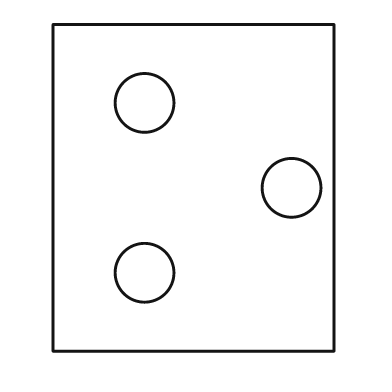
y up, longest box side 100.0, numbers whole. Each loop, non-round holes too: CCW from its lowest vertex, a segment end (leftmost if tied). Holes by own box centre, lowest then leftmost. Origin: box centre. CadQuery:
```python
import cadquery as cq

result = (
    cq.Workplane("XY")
    .moveTo(-43.0, -50.0)
    .lineTo(43.0, -50.0)
    .lineTo(43.0, 50.0)
    .lineTo(-43.0, 50.0)
    .close()
    .moveTo(-15.0, -26.0)
    .circle(9.0)
    .moveTo(30.0, 0.0)
    .circle(9.0)
    .moveTo(-15.0, 26.0)
    .circle(9.0)
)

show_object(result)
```